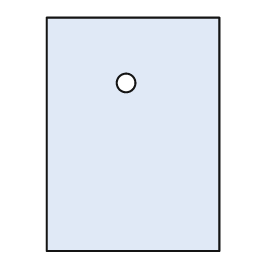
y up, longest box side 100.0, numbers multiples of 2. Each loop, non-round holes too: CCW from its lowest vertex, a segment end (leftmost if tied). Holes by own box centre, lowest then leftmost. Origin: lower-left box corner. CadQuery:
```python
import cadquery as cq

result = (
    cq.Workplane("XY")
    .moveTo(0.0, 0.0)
    .lineTo(74.0, 0.0)
    .lineTo(74.0, 100.0)
    .lineTo(0.0, 100.0)
    .close()
    .moveTo(34.0, 72.0)
    .circle(4.0)
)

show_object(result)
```